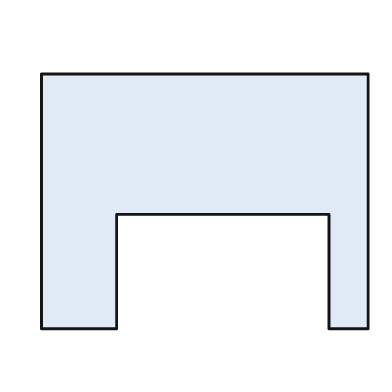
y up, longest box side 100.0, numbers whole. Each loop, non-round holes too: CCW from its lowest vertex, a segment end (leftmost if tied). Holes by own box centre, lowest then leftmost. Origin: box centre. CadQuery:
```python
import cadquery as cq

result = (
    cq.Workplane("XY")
    .moveTo(-50.0, -39.0)
    .lineTo(-27.0, -39.0)
    .lineTo(-27.0, -4.0)
    .lineTo(38.0, -4.0)
    .lineTo(38.0, -39.0)
    .lineTo(50.0, -39.0)
    .lineTo(50.0, 39.0)
    .lineTo(-50.0, 39.0)
    .close()
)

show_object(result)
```